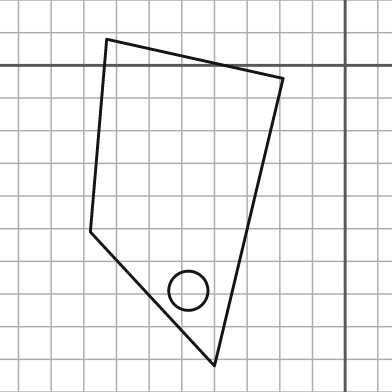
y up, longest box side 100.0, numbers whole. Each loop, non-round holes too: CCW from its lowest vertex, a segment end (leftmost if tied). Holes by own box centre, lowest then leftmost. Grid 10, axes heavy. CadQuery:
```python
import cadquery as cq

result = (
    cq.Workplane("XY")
    .moveTo(-40.0, -92.0)
    .lineTo(-19.0, -4.0)
    .lineTo(-73.0, 8.0)
    .lineTo(-78.0, -51.0)
    .close()
    .moveTo(-48.0, -69.0)
    .circle(6.0)
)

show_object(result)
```